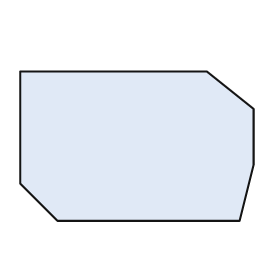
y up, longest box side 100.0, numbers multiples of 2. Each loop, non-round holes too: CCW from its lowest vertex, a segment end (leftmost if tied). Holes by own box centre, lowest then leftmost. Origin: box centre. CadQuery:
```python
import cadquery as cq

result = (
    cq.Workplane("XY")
    .moveTo(-34.0, -32.0)
    .lineTo(44.0, -32.0)
    .lineTo(50.0, -8.0)
    .lineTo(50.0, 16.0)
    .lineTo(30.0, 32.0)
    .lineTo(-50.0, 32.0)
    .lineTo(-50.0, -16.0)
    .close()
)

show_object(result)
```